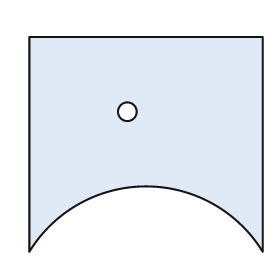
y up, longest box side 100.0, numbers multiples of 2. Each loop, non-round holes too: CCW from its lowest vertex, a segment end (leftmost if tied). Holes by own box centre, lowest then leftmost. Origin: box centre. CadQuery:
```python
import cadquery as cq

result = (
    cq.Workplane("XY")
    .moveTo(-50.0, -46.0)
    .threePointArc((0.0, -18.0), (50.0, -46.0))
    .lineTo(50.0, 46.0)
    .lineTo(-50.0, 46.0)
    .close()
    .moveTo(-8.0, 14.0)
    .circle(4.0)
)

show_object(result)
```